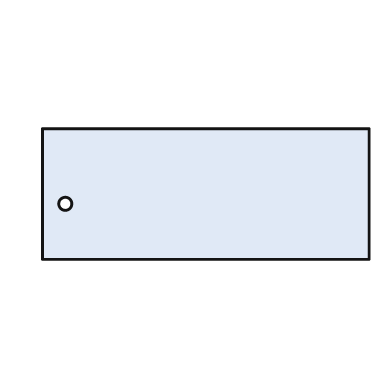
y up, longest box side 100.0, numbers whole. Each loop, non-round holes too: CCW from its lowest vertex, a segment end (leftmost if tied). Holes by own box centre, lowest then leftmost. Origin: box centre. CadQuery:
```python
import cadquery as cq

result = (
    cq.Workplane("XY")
    .moveTo(-50.0, -20.0)
    .lineTo(50.0, -20.0)
    .lineTo(50.0, 20.0)
    .lineTo(-50.0, 20.0)
    .close()
    .moveTo(-43.0, -3.0)
    .circle(2.0)
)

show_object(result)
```